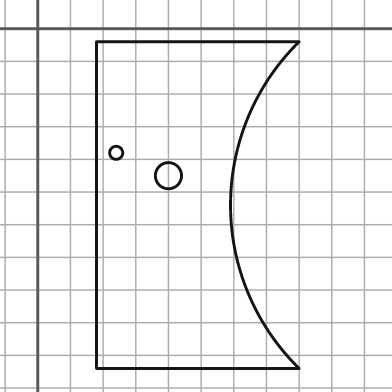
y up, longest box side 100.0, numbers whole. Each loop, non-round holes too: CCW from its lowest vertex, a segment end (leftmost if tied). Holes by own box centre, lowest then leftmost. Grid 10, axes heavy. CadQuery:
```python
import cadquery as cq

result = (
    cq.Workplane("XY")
    .moveTo(18.0, -104.0)
    .lineTo(80.0, -104.0)
    .threePointArc((59.0, -54.0), (80.0, -4.0))
    .lineTo(18.0, -4.0)
    .close()
    .moveTo(40.0, -45.0)
    .circle(4.0)
    .moveTo(24.0, -38.0)
    .circle(2.0)
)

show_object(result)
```